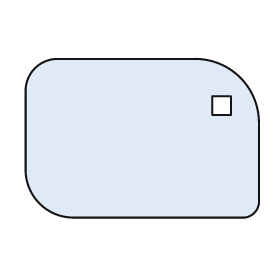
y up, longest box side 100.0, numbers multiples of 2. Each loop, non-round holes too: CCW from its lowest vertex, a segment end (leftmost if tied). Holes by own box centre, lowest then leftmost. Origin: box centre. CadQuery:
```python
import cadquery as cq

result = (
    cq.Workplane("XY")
    .moveTo(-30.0, -34.0)
    .lineTo(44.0, -34.0)
    .threePointArc((48.0, -32.0), (50.0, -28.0))
    .lineTo(50.0, 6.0)
    .threePointArc((42.0, 26.0), (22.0, 34.0))
    .lineTo(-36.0, 34.0)
    .threePointArc((-46.0, 30.0), (-50.0, 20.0))
    .lineTo(-50.0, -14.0)
    .threePointArc((-44.0, -28.0), (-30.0, -34.0))
    .close()
    .moveTo(30.0, 10.0)
    .lineTo(38.0, 10.0)
    .lineTo(38.0, 18.0)
    .lineTo(30.0, 18.0)
    .close()
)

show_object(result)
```